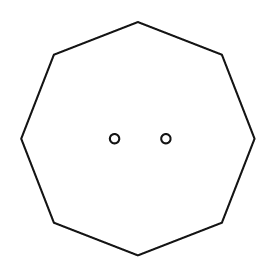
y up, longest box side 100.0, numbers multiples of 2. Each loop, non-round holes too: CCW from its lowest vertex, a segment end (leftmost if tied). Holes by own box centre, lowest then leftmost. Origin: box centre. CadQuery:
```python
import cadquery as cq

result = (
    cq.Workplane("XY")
    .moveTo(0.0, -50.0)
    .lineTo(36.0, -36.0)
    .lineTo(50.0, 0.0)
    .lineTo(36.0, 36.0)
    .lineTo(0.0, 50.0)
    .lineTo(-36.0, 36.0)
    .lineTo(-50.0, 0.0)
    .lineTo(-36.0, -36.0)
    .close()
    .moveTo(-10.0, 0.0)
    .circle(2.0)
    .moveTo(12.0, 0.0)
    .circle(2.0)
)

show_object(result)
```